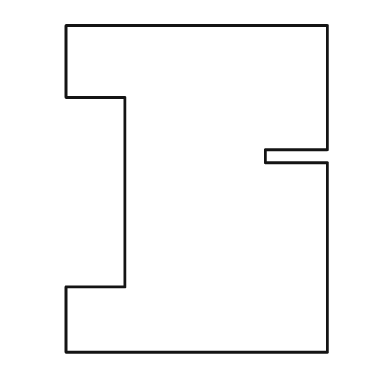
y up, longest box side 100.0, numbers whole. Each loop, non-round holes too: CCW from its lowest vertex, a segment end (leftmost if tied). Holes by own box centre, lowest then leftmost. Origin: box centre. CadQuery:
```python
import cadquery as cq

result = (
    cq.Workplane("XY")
    .moveTo(-40.0, -50.0)
    .lineTo(40.0, -50.0)
    .lineTo(40.0, 8.0)
    .lineTo(21.0, 8.0)
    .lineTo(21.0, 12.0)
    .lineTo(40.0, 12.0)
    .lineTo(40.0, 50.0)
    .lineTo(-40.0, 50.0)
    .lineTo(-40.0, 28.0)
    .lineTo(-22.0, 28.0)
    .lineTo(-22.0, -30.0)
    .lineTo(-40.0, -30.0)
    .close()
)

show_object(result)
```